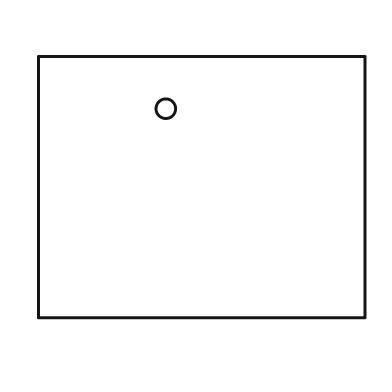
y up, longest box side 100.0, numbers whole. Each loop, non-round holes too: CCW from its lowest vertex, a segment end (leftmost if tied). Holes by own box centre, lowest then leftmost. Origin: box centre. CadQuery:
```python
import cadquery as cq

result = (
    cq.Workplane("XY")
    .moveTo(-50.0, -40.0)
    .lineTo(50.0, -40.0)
    .lineTo(50.0, 40.0)
    .lineTo(-50.0, 40.0)
    .close()
    .moveTo(-11.0, 24.0)
    .circle(3.0)
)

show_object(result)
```